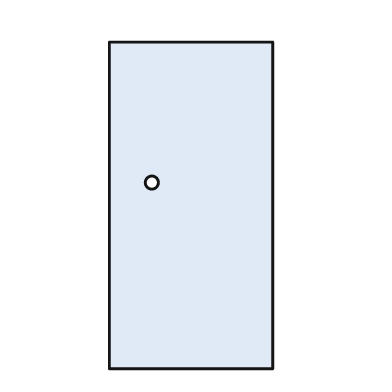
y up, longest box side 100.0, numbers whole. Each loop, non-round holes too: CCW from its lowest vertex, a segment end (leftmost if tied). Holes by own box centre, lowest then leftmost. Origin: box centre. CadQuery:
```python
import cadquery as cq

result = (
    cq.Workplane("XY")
    .moveTo(-25.0, -50.0)
    .lineTo(25.0, -50.0)
    .lineTo(25.0, 50.0)
    .lineTo(-25.0, 50.0)
    .close()
    .moveTo(-12.0, 7.0)
    .circle(2.0)
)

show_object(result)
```